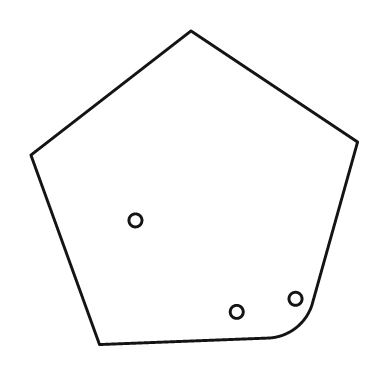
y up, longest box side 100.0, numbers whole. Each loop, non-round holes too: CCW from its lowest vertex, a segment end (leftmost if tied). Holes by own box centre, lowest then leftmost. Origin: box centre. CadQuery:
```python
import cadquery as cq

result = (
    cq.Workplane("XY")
    .moveTo(-29.0, -48.0)
    .lineTo(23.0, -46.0)
    .threePointArc((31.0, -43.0), (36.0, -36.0))
    .lineTo(50.0, 14.0)
    .lineTo(-1.0, 48.0)
    .lineTo(-50.0, 10.0)
    .close()
    .moveTo(13.0, -38.0)
    .circle(2.0)
    .moveTo(31.0, -34.0)
    .circle(2.0)
    .moveTo(-18.0, -10.0)
    .circle(2.0)
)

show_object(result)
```